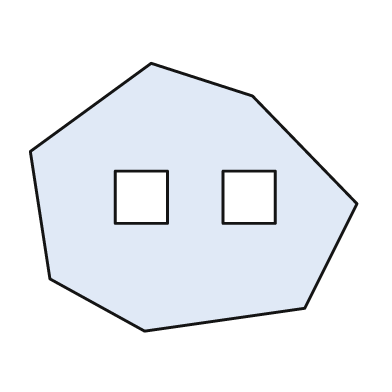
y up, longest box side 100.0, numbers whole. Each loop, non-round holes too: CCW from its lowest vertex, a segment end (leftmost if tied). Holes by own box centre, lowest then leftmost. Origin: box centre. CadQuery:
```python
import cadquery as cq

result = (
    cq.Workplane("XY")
    .moveTo(-15.0, -41.0)
    .lineTo(34.0, -34.0)
    .lineTo(50.0, -2.0)
    .lineTo(18.0, 31.0)
    .lineTo(-13.0, 41.0)
    .lineTo(-50.0, 14.0)
    .lineTo(-44.0, -25.0)
    .close()
    .moveTo(-24.0, -8.0)
    .lineTo(-8.0, -8.0)
    .lineTo(-8.0, 8.0)
    .lineTo(-24.0, 8.0)
    .close()
    .moveTo(9.0, -8.0)
    .lineTo(25.0, -8.0)
    .lineTo(25.0, 8.0)
    .lineTo(9.0, 8.0)
    .close()
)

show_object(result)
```